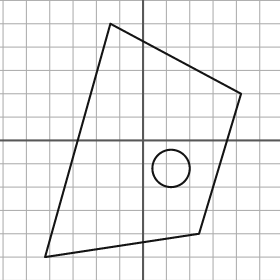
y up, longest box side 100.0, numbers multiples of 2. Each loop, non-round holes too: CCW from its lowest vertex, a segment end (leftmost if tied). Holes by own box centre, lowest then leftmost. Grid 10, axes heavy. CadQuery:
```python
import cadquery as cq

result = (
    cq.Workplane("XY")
    .moveTo(-42.0, -50.0)
    .lineTo(24.0, -40.0)
    .lineTo(42.0, 20.0)
    .lineTo(-14.0, 50.0)
    .close()
    .moveTo(12.0, -12.0)
    .circle(8.0)
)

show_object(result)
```